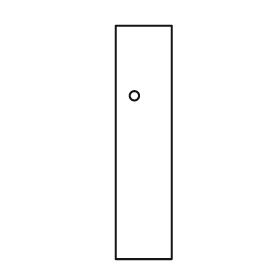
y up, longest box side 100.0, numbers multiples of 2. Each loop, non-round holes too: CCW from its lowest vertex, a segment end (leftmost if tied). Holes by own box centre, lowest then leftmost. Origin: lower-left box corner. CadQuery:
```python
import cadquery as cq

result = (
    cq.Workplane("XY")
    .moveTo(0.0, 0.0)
    .lineTo(24.0, 0.0)
    .lineTo(24.0, 100.0)
    .lineTo(0.0, 100.0)
    .close()
    .moveTo(8.0, 70.0)
    .circle(2.0)
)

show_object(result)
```